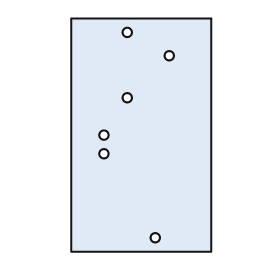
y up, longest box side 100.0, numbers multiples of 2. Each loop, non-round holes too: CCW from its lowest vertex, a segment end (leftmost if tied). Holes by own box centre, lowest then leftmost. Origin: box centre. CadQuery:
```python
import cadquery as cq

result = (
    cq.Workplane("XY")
    .moveTo(-30.0, -50.0)
    .lineTo(30.0, -50.0)
    .lineTo(30.0, 50.0)
    .lineTo(-30.0, 50.0)
    .close()
    .moveTo(6.0, -44.0)
    .circle(2.0)
    .moveTo(-16.0, -8.0)
    .circle(2.0)
    .moveTo(-16.0, 0.0)
    .circle(2.0)
    .moveTo(-6.0, 16.0)
    .circle(2.0)
    .moveTo(12.0, 34.0)
    .circle(2.0)
    .moveTo(-6.0, 44.0)
    .circle(2.0)
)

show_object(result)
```